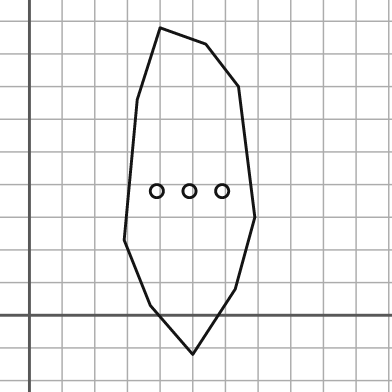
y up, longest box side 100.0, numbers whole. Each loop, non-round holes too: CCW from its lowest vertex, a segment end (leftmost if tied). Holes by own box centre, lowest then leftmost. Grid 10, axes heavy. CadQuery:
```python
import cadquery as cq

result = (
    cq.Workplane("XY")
    .moveTo(50.0, -12.0)
    .lineTo(63.0, 8.0)
    .lineTo(69.0, 30.0)
    .lineTo(64.0, 70.0)
    .lineTo(54.0, 83.0)
    .lineTo(40.0, 88.0)
    .lineTo(33.0, 66.0)
    .lineTo(29.0, 23.0)
    .lineTo(37.0, 3.0)
    .close()
    .moveTo(39.0, 38.0)
    .circle(2.0)
    .moveTo(49.0, 38.0)
    .circle(2.0)
    .moveTo(59.0, 38.0)
    .circle(2.0)
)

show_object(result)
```